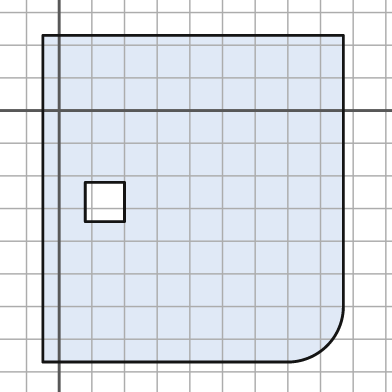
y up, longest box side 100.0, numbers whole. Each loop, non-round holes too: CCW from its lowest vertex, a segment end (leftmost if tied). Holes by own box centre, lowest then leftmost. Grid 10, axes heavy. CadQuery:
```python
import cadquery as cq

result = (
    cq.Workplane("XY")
    .moveTo(-5.0, -77.0)
    .lineTo(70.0, -77.0)
    .threePointArc((82.0, -72.0), (87.0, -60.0))
    .lineTo(87.0, 23.0)
    .lineTo(-5.0, 23.0)
    .close()
    .moveTo(8.0, -34.0)
    .lineTo(20.0, -34.0)
    .lineTo(20.0, -22.0)
    .lineTo(8.0, -22.0)
    .close()
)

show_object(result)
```